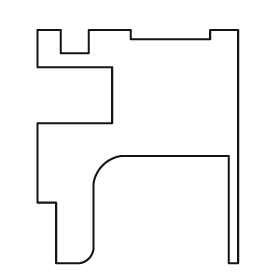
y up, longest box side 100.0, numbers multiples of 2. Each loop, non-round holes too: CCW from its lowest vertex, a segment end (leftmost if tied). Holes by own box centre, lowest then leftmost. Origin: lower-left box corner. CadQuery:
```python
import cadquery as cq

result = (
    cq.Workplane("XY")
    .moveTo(8.0, 0.0)
    .lineTo(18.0, 0.0)
    .threePointArc((22.0, 2.0), (24.0, 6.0))
    .lineTo(24.0, 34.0)
    .threePointArc((28.0, 42.0), (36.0, 46.0))
    .lineTo(82.0, 46.0)
    .lineTo(82.0, 0.0)
    .lineTo(86.0, 0.0)
    .lineTo(86.0, 100.0)
    .lineTo(74.0, 100.0)
    .lineTo(74.0, 96.0)
    .lineTo(40.0, 96.0)
    .lineTo(40.0, 100.0)
    .lineTo(22.0, 100.0)
    .lineTo(22.0, 90.0)
    .lineTo(10.0, 90.0)
    .lineTo(10.0, 100.0)
    .lineTo(0.0, 100.0)
    .lineTo(0.0, 84.0)
    .lineTo(32.0, 84.0)
    .lineTo(32.0, 60.0)
    .lineTo(0.0, 60.0)
    .lineTo(0.0, 26.0)
    .lineTo(8.0, 26.0)
    .close()
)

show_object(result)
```